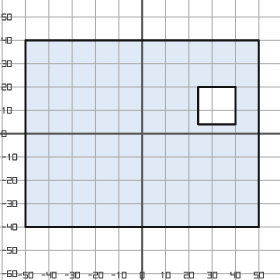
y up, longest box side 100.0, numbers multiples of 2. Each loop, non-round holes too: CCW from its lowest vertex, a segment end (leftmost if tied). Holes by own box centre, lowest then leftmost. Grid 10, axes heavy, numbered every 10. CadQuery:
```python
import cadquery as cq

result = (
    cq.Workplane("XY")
    .moveTo(-50.0, -40.0)
    .lineTo(50.0, -40.0)
    .lineTo(50.0, 40.0)
    .lineTo(-50.0, 40.0)
    .close()
    .moveTo(24.0, 4.0)
    .lineTo(40.0, 4.0)
    .lineTo(40.0, 20.0)
    .lineTo(24.0, 20.0)
    .close()
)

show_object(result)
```